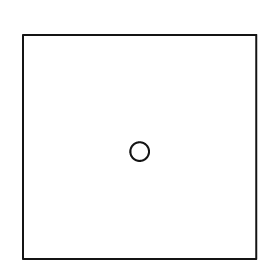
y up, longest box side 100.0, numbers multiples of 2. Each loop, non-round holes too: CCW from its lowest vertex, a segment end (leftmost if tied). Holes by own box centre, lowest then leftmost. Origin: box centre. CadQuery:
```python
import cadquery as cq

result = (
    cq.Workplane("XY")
    .moveTo(-50.0, -48.0)
    .lineTo(50.0, -48.0)
    .lineTo(50.0, 48.0)
    .lineTo(-50.0, 48.0)
    .close()
    .moveTo(0.0, -2.0)
    .circle(4.0)
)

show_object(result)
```